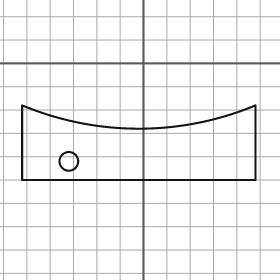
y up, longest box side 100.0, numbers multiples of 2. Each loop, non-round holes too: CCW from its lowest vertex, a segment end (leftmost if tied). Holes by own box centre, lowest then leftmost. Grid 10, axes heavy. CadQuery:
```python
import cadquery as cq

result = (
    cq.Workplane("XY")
    .moveTo(-52.0, -50.0)
    .lineTo(48.0, -50.0)
    .lineTo(48.0, -18.0)
    .threePointArc((-2.0, -28.0), (-52.0, -18.0))
    .close()
    .moveTo(-32.0, -42.0)
    .circle(4.0)
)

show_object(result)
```